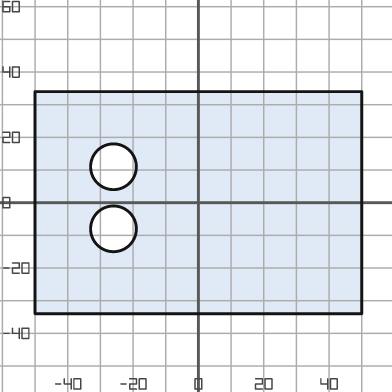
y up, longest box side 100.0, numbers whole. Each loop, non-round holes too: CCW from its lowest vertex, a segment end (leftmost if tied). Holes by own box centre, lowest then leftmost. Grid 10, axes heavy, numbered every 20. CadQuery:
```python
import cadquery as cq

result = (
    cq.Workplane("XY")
    .moveTo(-50.0, -34.0)
    .lineTo(50.0, -34.0)
    .lineTo(50.0, 34.0)
    .lineTo(-50.0, 34.0)
    .close()
    .moveTo(-26.0, -8.0)
    .circle(7.0)
    .moveTo(-26.0, 11.0)
    .circle(7.0)
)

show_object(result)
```